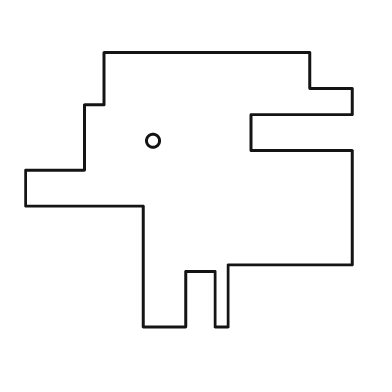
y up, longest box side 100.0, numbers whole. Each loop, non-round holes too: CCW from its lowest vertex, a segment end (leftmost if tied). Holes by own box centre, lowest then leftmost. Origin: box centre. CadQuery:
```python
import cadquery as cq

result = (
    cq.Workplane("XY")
    .moveTo(-14.0, -42.0)
    .lineTo(-1.0, -42.0)
    .lineTo(-1.0, -25.0)
    .lineTo(8.0, -25.0)
    .lineTo(8.0, -42.0)
    .lineTo(12.0, -42.0)
    .lineTo(12.0, -23.0)
    .lineTo(50.0, -23.0)
    .lineTo(50.0, 12.0)
    .lineTo(19.0, 12.0)
    .lineTo(19.0, 23.0)
    .lineTo(50.0, 23.0)
    .lineTo(50.0, 31.0)
    .lineTo(37.0, 31.0)
    .lineTo(37.0, 42.0)
    .lineTo(-26.0, 42.0)
    .lineTo(-26.0, 26.0)
    .lineTo(-32.0, 26.0)
    .lineTo(-32.0, 6.0)
    .lineTo(-50.0, 6.0)
    .lineTo(-50.0, -5.0)
    .lineTo(-14.0, -5.0)
    .close()
    .moveTo(-11.0, 15.0)
    .circle(2.0)
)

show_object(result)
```